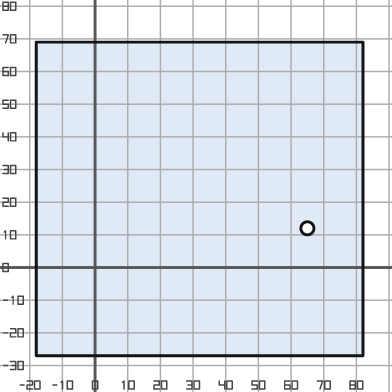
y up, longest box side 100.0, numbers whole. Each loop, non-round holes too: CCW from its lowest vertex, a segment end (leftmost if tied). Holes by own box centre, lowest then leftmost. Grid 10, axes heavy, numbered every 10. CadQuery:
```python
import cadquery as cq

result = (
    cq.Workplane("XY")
    .moveTo(-18.0, -27.0)
    .lineTo(82.0, -27.0)
    .lineTo(82.0, 69.0)
    .lineTo(-18.0, 69.0)
    .close()
    .moveTo(65.0, 12.0)
    .circle(2.0)
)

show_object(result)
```